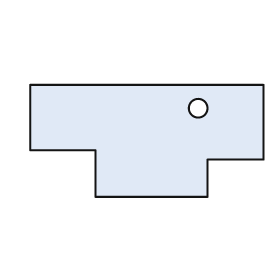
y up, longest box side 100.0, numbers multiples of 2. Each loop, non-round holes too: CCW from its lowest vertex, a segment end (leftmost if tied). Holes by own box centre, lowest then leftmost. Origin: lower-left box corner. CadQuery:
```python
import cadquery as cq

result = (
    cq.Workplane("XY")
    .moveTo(28.0, 0.0)
    .lineTo(76.0, 0.0)
    .lineTo(76.0, 16.0)
    .lineTo(100.0, 16.0)
    .lineTo(100.0, 48.0)
    .lineTo(0.0, 48.0)
    .lineTo(0.0, 20.0)
    .lineTo(28.0, 20.0)
    .close()
    .moveTo(72.0, 38.0)
    .circle(4.0)
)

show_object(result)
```